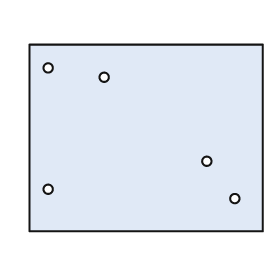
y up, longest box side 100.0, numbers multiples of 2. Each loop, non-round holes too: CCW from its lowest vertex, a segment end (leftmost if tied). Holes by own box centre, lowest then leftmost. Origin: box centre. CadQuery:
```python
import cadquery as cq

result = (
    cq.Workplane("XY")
    .moveTo(-50.0, -40.0)
    .lineTo(50.0, -40.0)
    .lineTo(50.0, 40.0)
    .lineTo(-50.0, 40.0)
    .close()
    .moveTo(38.0, -26.0)
    .circle(2.0)
    .moveTo(-42.0, -22.0)
    .circle(2.0)
    .moveTo(26.0, -10.0)
    .circle(2.0)
    .moveTo(-18.0, 26.0)
    .circle(2.0)
    .moveTo(-42.0, 30.0)
    .circle(2.0)
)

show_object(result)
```